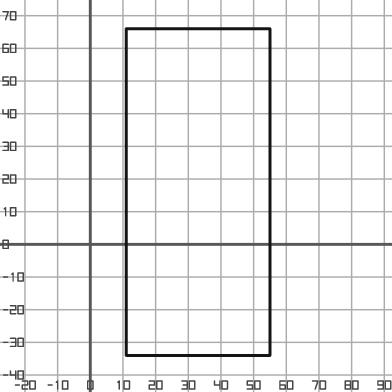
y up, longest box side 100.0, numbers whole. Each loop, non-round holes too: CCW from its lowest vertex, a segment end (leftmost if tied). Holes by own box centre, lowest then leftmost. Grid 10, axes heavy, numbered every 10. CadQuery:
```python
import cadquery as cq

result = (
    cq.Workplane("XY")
    .moveTo(11.0, -34.0)
    .lineTo(55.0, -34.0)
    .lineTo(55.0, 66.0)
    .lineTo(11.0, 66.0)
    .close()
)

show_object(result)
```